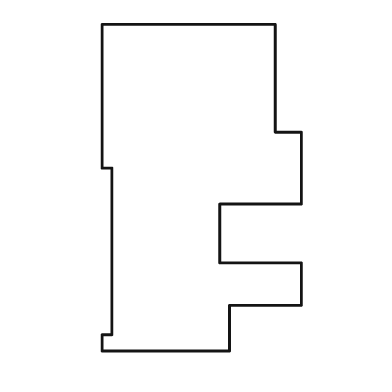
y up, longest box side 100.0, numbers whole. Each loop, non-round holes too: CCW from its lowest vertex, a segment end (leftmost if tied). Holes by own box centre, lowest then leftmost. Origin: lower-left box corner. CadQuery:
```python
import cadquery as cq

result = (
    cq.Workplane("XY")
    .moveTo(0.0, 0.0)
    .lineTo(39.0, 0.0)
    .lineTo(39.0, 14.0)
    .lineTo(61.0, 14.0)
    .lineTo(61.0, 27.0)
    .lineTo(36.0, 27.0)
    .lineTo(36.0, 45.0)
    .lineTo(61.0, 45.0)
    .lineTo(61.0, 67.0)
    .lineTo(53.0, 67.0)
    .lineTo(53.0, 100.0)
    .lineTo(0.0, 100.0)
    .lineTo(0.0, 56.0)
    .lineTo(3.0, 56.0)
    .lineTo(3.0, 5.0)
    .lineTo(0.0, 5.0)
    .close()
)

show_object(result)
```